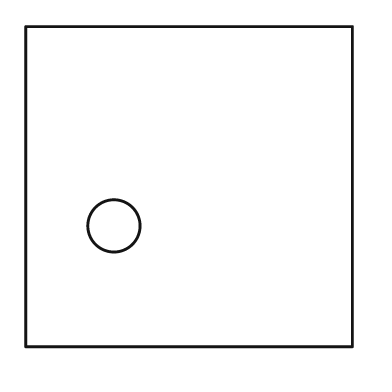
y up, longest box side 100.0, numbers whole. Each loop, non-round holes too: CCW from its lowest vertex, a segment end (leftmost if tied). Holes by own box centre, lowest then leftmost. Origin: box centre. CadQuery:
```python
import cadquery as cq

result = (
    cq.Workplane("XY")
    .moveTo(-50.0, -49.0)
    .lineTo(50.0, -49.0)
    .lineTo(50.0, 49.0)
    .lineTo(-50.0, 49.0)
    .close()
    .moveTo(-23.0, -12.0)
    .circle(8.0)
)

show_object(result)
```